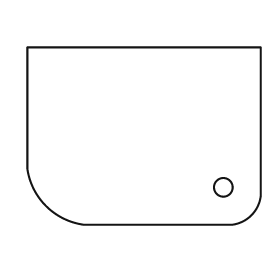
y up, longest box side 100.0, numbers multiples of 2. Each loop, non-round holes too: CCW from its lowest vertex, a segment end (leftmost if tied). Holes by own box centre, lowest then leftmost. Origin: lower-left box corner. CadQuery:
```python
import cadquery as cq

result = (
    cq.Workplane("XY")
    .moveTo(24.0, 0.0)
    .lineTo(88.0, 0.0)
    .threePointArc((96.0, 4.0), (100.0, 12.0))
    .lineTo(100.0, 76.0)
    .lineTo(0.0, 76.0)
    .lineTo(0.0, 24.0)
    .threePointArc((8.0, 8.0), (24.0, 0.0))
    .close()
    .moveTo(84.0, 16.0)
    .circle(4.0)
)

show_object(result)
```